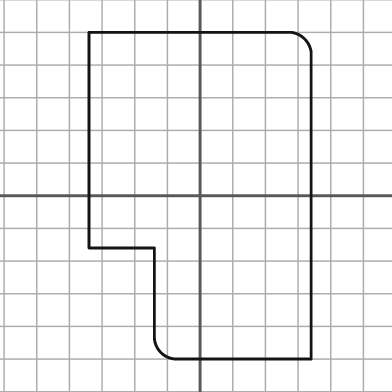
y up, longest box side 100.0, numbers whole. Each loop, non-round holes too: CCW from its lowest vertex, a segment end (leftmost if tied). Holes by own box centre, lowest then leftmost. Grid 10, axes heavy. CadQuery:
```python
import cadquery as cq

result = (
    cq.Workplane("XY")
    .moveTo(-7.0, -50.0)
    .lineTo(34.0, -50.0)
    .lineTo(34.0, 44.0)
    .threePointArc((32.0, 48.0), (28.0, 50.0))
    .lineTo(-34.0, 50.0)
    .lineTo(-34.0, -16.0)
    .lineTo(-14.0, -16.0)
    .lineTo(-14.0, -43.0)
    .threePointArc((-12.0, -48.0), (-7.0, -50.0))
    .close()
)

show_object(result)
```